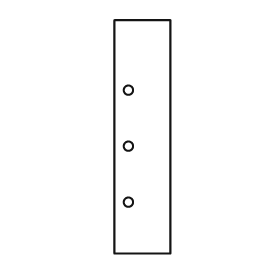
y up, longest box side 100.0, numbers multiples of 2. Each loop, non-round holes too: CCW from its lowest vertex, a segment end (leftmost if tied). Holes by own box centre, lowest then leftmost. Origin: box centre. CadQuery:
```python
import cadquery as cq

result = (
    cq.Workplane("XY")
    .moveTo(-12.0, -50.0)
    .lineTo(12.0, -50.0)
    .lineTo(12.0, 50.0)
    .lineTo(-12.0, 50.0)
    .close()
    .moveTo(-6.0, -28.0)
    .circle(2.0)
    .moveTo(-6.0, -4.0)
    .circle(2.0)
    .moveTo(-6.0, 20.0)
    .circle(2.0)
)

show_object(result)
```